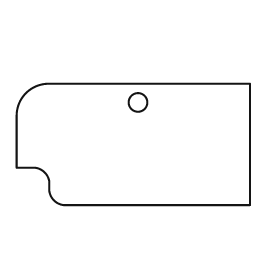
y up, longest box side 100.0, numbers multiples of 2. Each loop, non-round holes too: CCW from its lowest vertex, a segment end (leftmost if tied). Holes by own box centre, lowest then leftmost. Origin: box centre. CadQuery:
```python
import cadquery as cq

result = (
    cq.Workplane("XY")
    .moveTo(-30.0, -26.0)
    .lineTo(50.0, -26.0)
    .lineTo(50.0, 26.0)
    .lineTo(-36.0, 26.0)
    .threePointArc((-46.0, 22.0), (-50.0, 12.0))
    .lineTo(-50.0, -10.0)
    .lineTo(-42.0, -10.0)
    .threePointArc((-38.0, -12.0), (-36.0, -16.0))
    .lineTo(-36.0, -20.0)
    .threePointArc((-34.0, -24.0), (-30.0, -26.0))
    .close()
    .moveTo(2.0, 18.0)
    .circle(4.0)
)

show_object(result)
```